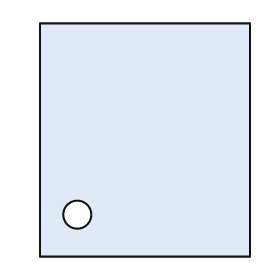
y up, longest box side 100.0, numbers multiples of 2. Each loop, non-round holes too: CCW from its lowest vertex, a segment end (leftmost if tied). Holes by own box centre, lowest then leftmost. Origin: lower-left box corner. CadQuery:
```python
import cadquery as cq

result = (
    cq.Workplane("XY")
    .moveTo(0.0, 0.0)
    .lineTo(90.0, 0.0)
    .lineTo(90.0, 100.0)
    .lineTo(0.0, 100.0)
    .close()
    .moveTo(16.0, 18.0)
    .circle(6.0)
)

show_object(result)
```